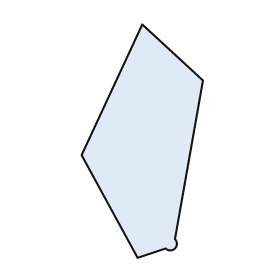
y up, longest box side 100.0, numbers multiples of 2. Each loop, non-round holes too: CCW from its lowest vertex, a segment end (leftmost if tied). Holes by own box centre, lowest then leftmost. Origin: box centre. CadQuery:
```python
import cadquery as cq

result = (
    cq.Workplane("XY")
    .moveTo(-2.0, -50.0)
    .lineTo(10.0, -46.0)
    .threePointArc((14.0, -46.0), (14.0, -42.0))
    .lineTo(26.0, 26.0)
    .lineTo(0.0, 50.0)
    .lineTo(-26.0, -6.0)
    .close()
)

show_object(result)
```